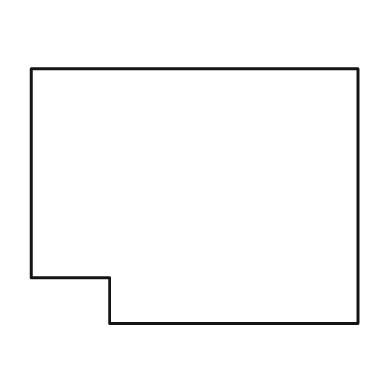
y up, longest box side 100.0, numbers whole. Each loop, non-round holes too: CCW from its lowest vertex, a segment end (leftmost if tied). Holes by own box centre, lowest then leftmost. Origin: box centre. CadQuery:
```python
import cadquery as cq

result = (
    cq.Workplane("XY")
    .moveTo(-26.0, -39.0)
    .lineTo(50.0, -39.0)
    .lineTo(50.0, 39.0)
    .lineTo(-50.0, 39.0)
    .lineTo(-50.0, -25.0)
    .lineTo(-26.0, -25.0)
    .close()
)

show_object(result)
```